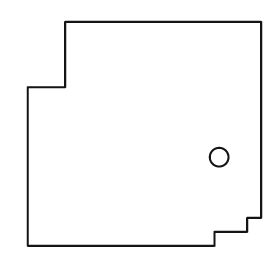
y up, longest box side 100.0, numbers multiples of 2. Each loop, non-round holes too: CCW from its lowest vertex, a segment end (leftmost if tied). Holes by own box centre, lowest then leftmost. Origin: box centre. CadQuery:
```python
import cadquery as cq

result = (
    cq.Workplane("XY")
    .moveTo(-50.0, -48.0)
    .lineTo(30.0, -48.0)
    .lineTo(30.0, -42.0)
    .lineTo(44.0, -42.0)
    .lineTo(44.0, -36.0)
    .lineTo(50.0, -36.0)
    .lineTo(50.0, 48.0)
    .lineTo(-34.0, 48.0)
    .lineTo(-34.0, 20.0)
    .lineTo(-50.0, 20.0)
    .close()
    .moveTo(32.0, -10.0)
    .circle(4.0)
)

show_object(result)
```